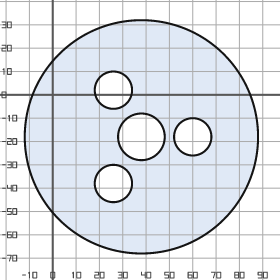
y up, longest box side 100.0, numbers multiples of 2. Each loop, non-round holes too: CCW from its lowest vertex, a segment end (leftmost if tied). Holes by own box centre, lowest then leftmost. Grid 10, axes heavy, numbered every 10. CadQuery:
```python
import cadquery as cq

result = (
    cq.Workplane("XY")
    .moveTo(38.0, -18.0)
    .circle(50.0)
    .moveTo(26.0, -38.0)
    .circle(8.0)
    .moveTo(38.0, -18.0)
    .circle(10.0)
    .moveTo(60.0, -18.0)
    .circle(8.0)
    .moveTo(26.0, 2.0)
    .circle(8.0)
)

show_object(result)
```